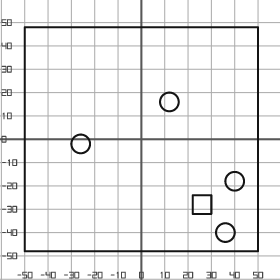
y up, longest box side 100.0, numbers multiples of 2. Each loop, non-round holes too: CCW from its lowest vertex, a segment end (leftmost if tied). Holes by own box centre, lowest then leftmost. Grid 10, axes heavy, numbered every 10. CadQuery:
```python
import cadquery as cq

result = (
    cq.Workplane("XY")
    .moveTo(-50.0, -48.0)
    .lineTo(50.0, -48.0)
    .lineTo(50.0, 48.0)
    .lineTo(-50.0, 48.0)
    .close()
    .moveTo(36.0, -40.0)
    .circle(4.0)
    .moveTo(22.0, -32.0)
    .lineTo(30.0, -32.0)
    .lineTo(30.0, -24.0)
    .lineTo(22.0, -24.0)
    .close()
    .moveTo(40.0, -18.0)
    .circle(4.0)
    .moveTo(-26.0, -2.0)
    .circle(4.0)
    .moveTo(12.0, 16.0)
    .circle(4.0)
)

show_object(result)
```